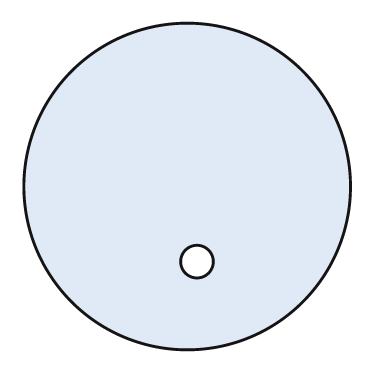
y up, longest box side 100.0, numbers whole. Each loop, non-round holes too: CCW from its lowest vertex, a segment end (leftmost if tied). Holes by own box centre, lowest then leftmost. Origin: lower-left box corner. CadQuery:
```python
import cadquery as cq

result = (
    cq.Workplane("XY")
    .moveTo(50.0, 50.0)
    .circle(50.0)
    .moveTo(53.0, 27.0)
    .circle(5.0)
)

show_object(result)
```